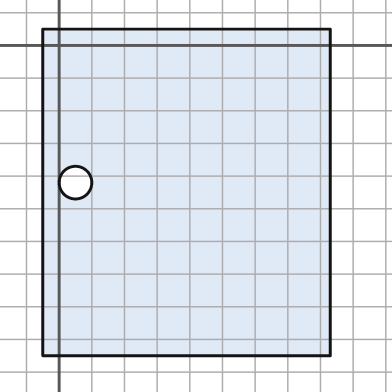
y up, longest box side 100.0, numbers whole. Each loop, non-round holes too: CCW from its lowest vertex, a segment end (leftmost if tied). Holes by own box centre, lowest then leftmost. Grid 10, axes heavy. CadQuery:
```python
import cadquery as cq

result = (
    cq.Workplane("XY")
    .moveTo(-5.0, -95.0)
    .lineTo(83.0, -95.0)
    .lineTo(83.0, 5.0)
    .lineTo(-5.0, 5.0)
    .close()
    .moveTo(5.0, -42.0)
    .circle(5.0)
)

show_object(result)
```